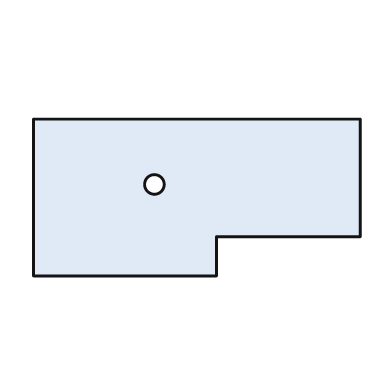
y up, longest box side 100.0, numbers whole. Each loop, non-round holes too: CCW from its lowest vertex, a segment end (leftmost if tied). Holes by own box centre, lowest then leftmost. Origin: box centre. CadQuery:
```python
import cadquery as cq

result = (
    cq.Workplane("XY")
    .moveTo(-50.0, -24.0)
    .lineTo(6.0, -24.0)
    .lineTo(6.0, -12.0)
    .lineTo(50.0, -12.0)
    .lineTo(50.0, 24.0)
    .lineTo(-50.0, 24.0)
    .close()
    .moveTo(-13.0, 4.0)
    .circle(3.0)
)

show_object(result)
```